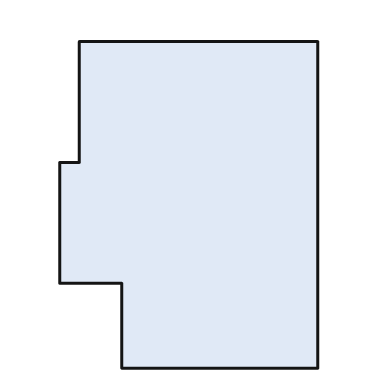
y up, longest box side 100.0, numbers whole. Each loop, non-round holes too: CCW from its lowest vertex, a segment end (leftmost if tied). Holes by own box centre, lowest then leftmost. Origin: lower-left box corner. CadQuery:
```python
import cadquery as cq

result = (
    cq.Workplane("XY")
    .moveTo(19.0, 0.0)
    .lineTo(79.0, 0.0)
    .lineTo(79.0, 100.0)
    .lineTo(6.0, 100.0)
    .lineTo(6.0, 63.0)
    .lineTo(0.0, 63.0)
    .lineTo(0.0, 26.0)
    .lineTo(19.0, 26.0)
    .close()
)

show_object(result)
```